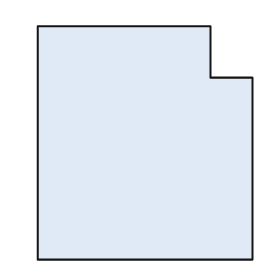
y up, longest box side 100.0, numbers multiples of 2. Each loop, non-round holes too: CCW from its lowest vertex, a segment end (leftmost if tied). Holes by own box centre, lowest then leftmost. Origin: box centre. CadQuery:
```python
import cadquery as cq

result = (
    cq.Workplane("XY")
    .moveTo(-46.0, -50.0)
    .lineTo(46.0, -50.0)
    .lineTo(46.0, 28.0)
    .lineTo(28.0, 28.0)
    .lineTo(28.0, 50.0)
    .lineTo(-46.0, 50.0)
    .close()
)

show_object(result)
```